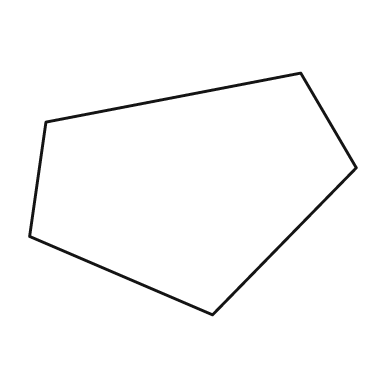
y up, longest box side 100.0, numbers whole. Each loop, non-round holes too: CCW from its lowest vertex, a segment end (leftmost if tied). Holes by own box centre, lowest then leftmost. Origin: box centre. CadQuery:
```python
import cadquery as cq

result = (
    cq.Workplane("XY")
    .moveTo(6.0, -37.0)
    .lineTo(50.0, 8.0)
    .lineTo(33.0, 37.0)
    .lineTo(-45.0, 22.0)
    .lineTo(-50.0, -13.0)
    .close()
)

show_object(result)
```